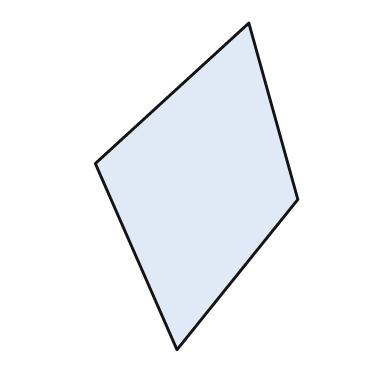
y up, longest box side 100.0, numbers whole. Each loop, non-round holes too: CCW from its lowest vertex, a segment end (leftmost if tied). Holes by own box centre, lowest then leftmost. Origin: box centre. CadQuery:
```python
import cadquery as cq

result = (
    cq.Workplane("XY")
    .moveTo(-6.0, -50.0)
    .lineTo(31.0, -4.0)
    .lineTo(16.0, 50.0)
    .lineTo(-31.0, 7.0)
    .close()
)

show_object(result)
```